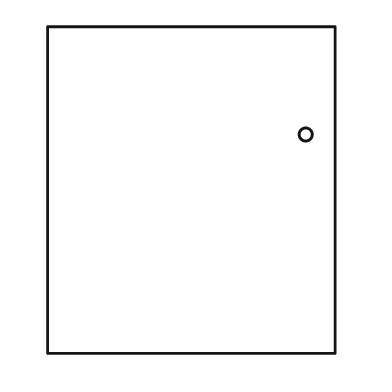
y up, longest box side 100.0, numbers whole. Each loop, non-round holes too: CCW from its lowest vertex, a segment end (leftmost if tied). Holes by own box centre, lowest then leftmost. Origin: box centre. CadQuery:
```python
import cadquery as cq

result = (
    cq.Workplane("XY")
    .moveTo(-44.0, -50.0)
    .lineTo(44.0, -50.0)
    .lineTo(44.0, 50.0)
    .lineTo(-44.0, 50.0)
    .close()
    .moveTo(35.0, 17.0)
    .circle(2.0)
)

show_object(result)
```